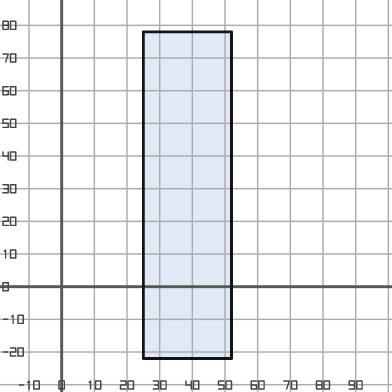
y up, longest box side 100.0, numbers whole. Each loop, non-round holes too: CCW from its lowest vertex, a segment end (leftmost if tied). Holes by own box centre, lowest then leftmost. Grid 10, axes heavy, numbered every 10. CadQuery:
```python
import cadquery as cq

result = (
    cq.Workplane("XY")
    .moveTo(25.0, -22.0)
    .lineTo(52.0, -22.0)
    .lineTo(52.0, 78.0)
    .lineTo(25.0, 78.0)
    .close()
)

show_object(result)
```